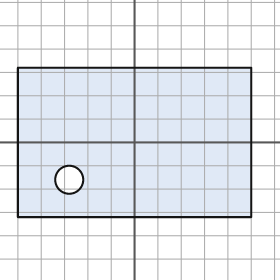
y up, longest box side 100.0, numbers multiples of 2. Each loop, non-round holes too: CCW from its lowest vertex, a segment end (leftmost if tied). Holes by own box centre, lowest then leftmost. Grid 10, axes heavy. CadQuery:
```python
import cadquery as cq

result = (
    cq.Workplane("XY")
    .moveTo(-50.0, -32.0)
    .lineTo(50.0, -32.0)
    .lineTo(50.0, 32.0)
    .lineTo(-50.0, 32.0)
    .close()
    .moveTo(-28.0, -16.0)
    .circle(6.0)
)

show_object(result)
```